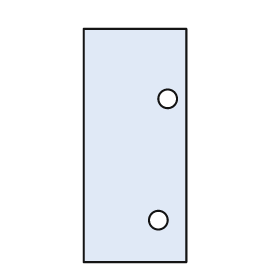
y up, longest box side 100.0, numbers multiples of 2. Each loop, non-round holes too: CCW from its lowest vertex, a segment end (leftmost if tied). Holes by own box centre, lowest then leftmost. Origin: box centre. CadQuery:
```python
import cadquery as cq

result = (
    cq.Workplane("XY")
    .moveTo(-22.0, -50.0)
    .lineTo(22.0, -50.0)
    .lineTo(22.0, 50.0)
    .lineTo(-22.0, 50.0)
    .close()
    .moveTo(10.0, -32.0)
    .circle(4.0)
    .moveTo(14.0, 20.0)
    .circle(4.0)
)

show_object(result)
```